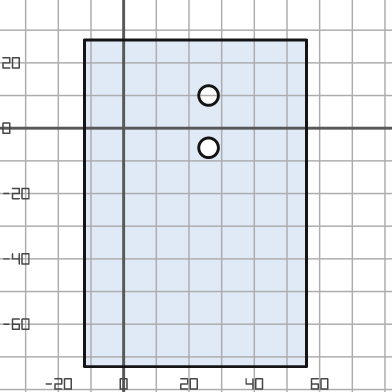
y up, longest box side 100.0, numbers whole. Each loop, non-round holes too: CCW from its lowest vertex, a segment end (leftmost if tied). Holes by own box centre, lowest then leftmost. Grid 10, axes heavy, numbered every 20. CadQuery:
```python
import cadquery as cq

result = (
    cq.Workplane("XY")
    .moveTo(-12.0, -73.0)
    .lineTo(56.0, -73.0)
    .lineTo(56.0, 27.0)
    .lineTo(-12.0, 27.0)
    .close()
    .moveTo(26.0, -6.0)
    .circle(3.0)
    .moveTo(26.0, 10.0)
    .circle(3.0)
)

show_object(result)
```